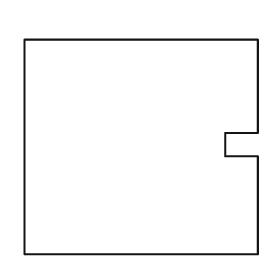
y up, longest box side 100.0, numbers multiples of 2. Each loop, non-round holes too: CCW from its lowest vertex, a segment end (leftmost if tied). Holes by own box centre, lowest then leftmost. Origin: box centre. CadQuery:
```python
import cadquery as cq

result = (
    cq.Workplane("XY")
    .moveTo(-50.0, -46.0)
    .lineTo(50.0, -46.0)
    .lineTo(50.0, -4.0)
    .lineTo(36.0, -4.0)
    .lineTo(36.0, 6.0)
    .lineTo(50.0, 6.0)
    .lineTo(50.0, 46.0)
    .lineTo(-50.0, 46.0)
    .close()
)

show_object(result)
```